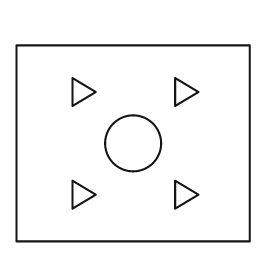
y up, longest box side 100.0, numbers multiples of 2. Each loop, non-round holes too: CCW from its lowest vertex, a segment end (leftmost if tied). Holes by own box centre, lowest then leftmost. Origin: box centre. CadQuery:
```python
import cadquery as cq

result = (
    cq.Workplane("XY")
    .moveTo(-50.0, -42.0)
    .lineTo(50.0, -42.0)
    .lineTo(50.0, 42.0)
    .lineTo(-50.0, 42.0)
    .close()
    .moveTo(-26.0, -28.0)
    .lineTo(-16.0, -22.0)
    .lineTo(-26.0, -16.0)
    .close()
    .moveTo(18.0, -28.0)
    .lineTo(28.0, -22.0)
    .lineTo(18.0, -16.0)
    .close()
    .moveTo(0.0, 0.0)
    .circle(12.0)
    .moveTo(-26.0, 16.0)
    .lineTo(-16.0, 22.0)
    .lineTo(-26.0, 28.0)
    .close()
    .moveTo(18.0, 16.0)
    .lineTo(28.0, 22.0)
    .lineTo(18.0, 28.0)
    .close()
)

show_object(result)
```